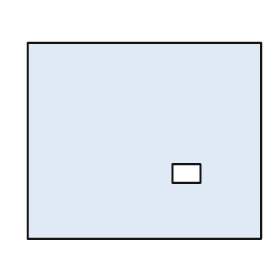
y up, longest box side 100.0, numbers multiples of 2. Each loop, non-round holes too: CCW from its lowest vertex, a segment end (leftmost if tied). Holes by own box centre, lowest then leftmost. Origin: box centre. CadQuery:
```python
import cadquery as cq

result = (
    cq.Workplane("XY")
    .moveTo(-50.0, -42.0)
    .lineTo(50.0, -42.0)
    .lineTo(50.0, 42.0)
    .lineTo(-50.0, 42.0)
    .close()
    .moveTo(12.0, -18.0)
    .lineTo(24.0, -18.0)
    .lineTo(24.0, -10.0)
    .lineTo(12.0, -10.0)
    .close()
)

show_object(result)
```